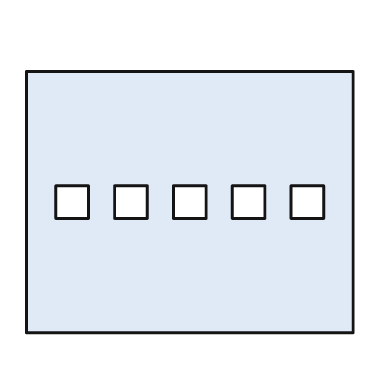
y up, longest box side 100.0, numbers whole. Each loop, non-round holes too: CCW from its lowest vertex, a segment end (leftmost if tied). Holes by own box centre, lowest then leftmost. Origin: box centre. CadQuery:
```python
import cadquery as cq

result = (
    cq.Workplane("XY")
    .moveTo(-50.0, -40.0)
    .lineTo(50.0, -40.0)
    .lineTo(50.0, 40.0)
    .lineTo(-50.0, 40.0)
    .close()
    .moveTo(-41.0, -5.0)
    .lineTo(-31.0, -5.0)
    .lineTo(-31.0, 5.0)
    .lineTo(-41.0, 5.0)
    .close()
    .moveTo(-23.0, -5.0)
    .lineTo(-13.0, -5.0)
    .lineTo(-13.0, 5.0)
    .lineTo(-23.0, 5.0)
    .close()
    .moveTo(-5.0, -5.0)
    .lineTo(5.0, -5.0)
    .lineTo(5.0, 5.0)
    .lineTo(-5.0, 5.0)
    .close()
    .moveTo(13.0, -5.0)
    .lineTo(23.0, -5.0)
    .lineTo(23.0, 5.0)
    .lineTo(13.0, 5.0)
    .close()
    .moveTo(31.0, -5.0)
    .lineTo(41.0, -5.0)
    .lineTo(41.0, 5.0)
    .lineTo(31.0, 5.0)
    .close()
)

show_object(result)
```